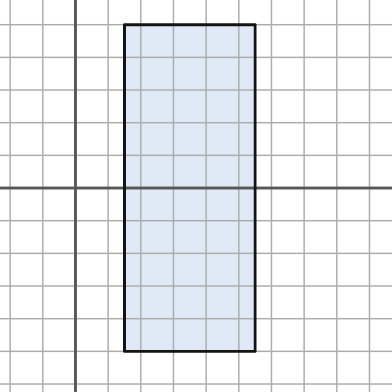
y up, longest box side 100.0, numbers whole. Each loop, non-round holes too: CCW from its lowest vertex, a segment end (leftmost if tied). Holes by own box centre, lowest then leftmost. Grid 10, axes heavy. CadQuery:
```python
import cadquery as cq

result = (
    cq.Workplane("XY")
    .moveTo(15.0, -50.0)
    .lineTo(55.0, -50.0)
    .lineTo(55.0, 50.0)
    .lineTo(15.0, 50.0)
    .close()
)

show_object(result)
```